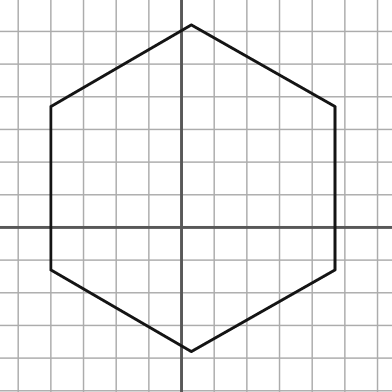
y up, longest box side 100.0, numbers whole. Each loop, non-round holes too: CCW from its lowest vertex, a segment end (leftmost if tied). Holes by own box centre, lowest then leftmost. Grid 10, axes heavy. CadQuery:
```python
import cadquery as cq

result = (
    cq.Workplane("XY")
    .moveTo(3.0, -38.0)
    .lineTo(47.0, -13.0)
    .lineTo(47.0, 37.0)
    .lineTo(3.0, 62.0)
    .lineTo(-40.0, 37.0)
    .lineTo(-40.0, -13.0)
    .close()
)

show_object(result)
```